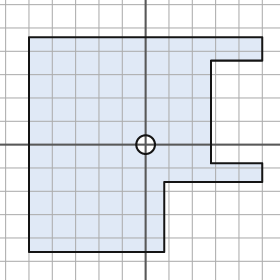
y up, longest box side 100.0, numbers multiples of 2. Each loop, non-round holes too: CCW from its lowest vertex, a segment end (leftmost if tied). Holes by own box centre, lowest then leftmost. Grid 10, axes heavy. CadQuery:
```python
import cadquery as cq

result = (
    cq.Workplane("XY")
    .moveTo(-50.0, -46.0)
    .lineTo(8.0, -46.0)
    .lineTo(8.0, -16.0)
    .lineTo(50.0, -16.0)
    .lineTo(50.0, -8.0)
    .lineTo(28.0, -8.0)
    .lineTo(28.0, 36.0)
    .lineTo(50.0, 36.0)
    .lineTo(50.0, 46.0)
    .lineTo(-50.0, 46.0)
    .close()
    .moveTo(0.0, 0.0)
    .circle(4.0)
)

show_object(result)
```